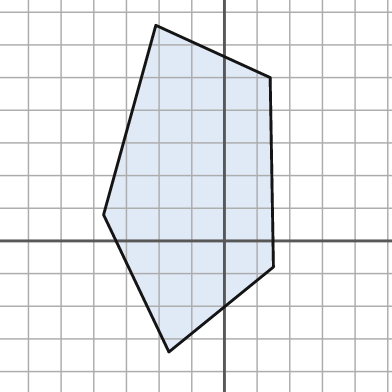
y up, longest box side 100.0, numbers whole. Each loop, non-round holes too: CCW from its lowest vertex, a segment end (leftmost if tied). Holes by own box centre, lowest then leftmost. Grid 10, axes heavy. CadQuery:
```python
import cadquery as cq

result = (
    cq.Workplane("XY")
    .moveTo(-17.0, -34.0)
    .lineTo(15.0, -8.0)
    .lineTo(14.0, 50.0)
    .lineTo(-21.0, 66.0)
    .lineTo(-37.0, 8.0)
    .close()
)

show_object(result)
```